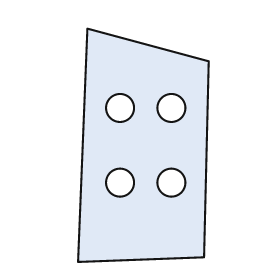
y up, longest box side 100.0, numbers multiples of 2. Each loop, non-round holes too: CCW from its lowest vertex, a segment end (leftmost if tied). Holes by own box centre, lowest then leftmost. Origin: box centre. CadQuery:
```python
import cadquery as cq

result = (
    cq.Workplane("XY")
    .moveTo(-28.0, -50.0)
    .lineTo(26.0, -48.0)
    .lineTo(28.0, 36.0)
    .lineTo(-24.0, 50.0)
    .close()
    .moveTo(-10.0, -16.0)
    .circle(6.0)
    .moveTo(12.0, -16.0)
    .circle(6.0)
    .moveTo(-10.0, 16.0)
    .circle(6.0)
    .moveTo(12.0, 16.0)
    .circle(6.0)
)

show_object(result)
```